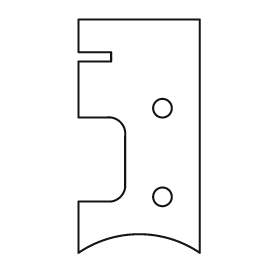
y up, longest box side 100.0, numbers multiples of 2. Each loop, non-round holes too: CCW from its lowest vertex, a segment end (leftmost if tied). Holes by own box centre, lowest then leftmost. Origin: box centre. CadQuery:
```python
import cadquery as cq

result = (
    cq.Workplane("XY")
    .moveTo(-26.0, -50.0)
    .threePointArc((0.0, -42.0), (26.0, -50.0))
    .lineTo(26.0, 50.0)
    .lineTo(-26.0, 50.0)
    .lineTo(-26.0, 36.0)
    .lineTo(-12.0, 36.0)
    .lineTo(-12.0, 32.0)
    .lineTo(-26.0, 32.0)
    .lineTo(-26.0, 8.0)
    .lineTo(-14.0, 8.0)
    .threePointArc((-8.0, 6.0), (-6.0, 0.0))
    .lineTo(-6.0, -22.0)
    .threePointArc((-8.0, -26.0), (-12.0, -28.0))
    .lineTo(-26.0, -28.0)
    .close()
    .moveTo(10.0, -26.0)
    .circle(4.0)
    .moveTo(10.0, 12.0)
    .circle(4.0)
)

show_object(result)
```